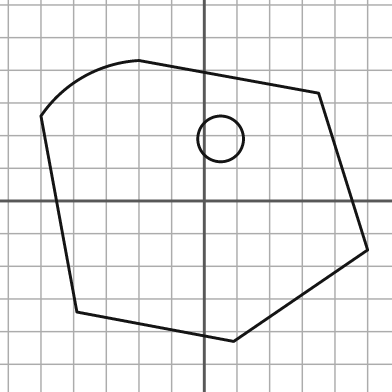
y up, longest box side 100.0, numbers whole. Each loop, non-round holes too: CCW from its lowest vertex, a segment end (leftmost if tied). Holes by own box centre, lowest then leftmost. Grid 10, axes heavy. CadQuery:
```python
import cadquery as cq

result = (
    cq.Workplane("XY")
    .moveTo(9.0, -43.0)
    .lineTo(50.0, -15.0)
    .lineTo(35.0, 33.0)
    .lineTo(-20.0, 43.0)
    .threePointArc((-37.0, 38.0), (-50.0, 26.0))
    .lineTo(-39.0, -34.0)
    .close()
    .moveTo(5.0, 19.0)
    .circle(7.0)
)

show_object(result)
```